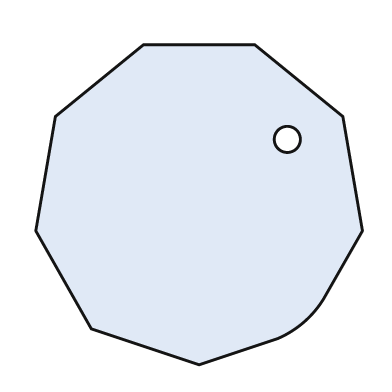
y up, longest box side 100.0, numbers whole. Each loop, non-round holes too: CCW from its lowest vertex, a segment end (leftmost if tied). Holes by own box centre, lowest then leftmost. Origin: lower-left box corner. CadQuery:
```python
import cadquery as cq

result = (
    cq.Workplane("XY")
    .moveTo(50.0, 0.0)
    .lineTo(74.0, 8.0)
    .threePointArc((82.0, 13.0), (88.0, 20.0))
    .lineTo(100.0, 41.0)
    .lineTo(94.0, 76.0)
    .lineTo(67.0, 98.0)
    .lineTo(33.0, 98.0)
    .lineTo(6.0, 76.0)
    .lineTo(0.0, 41.0)
    .lineTo(17.0, 11.0)
    .close()
    .moveTo(77.0, 69.0)
    .circle(4.0)
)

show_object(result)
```